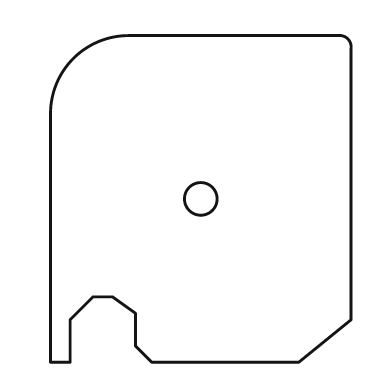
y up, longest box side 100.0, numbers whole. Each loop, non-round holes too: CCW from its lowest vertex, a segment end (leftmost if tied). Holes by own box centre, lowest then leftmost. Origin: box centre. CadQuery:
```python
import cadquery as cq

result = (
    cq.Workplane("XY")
    .moveTo(-46.0, -50.0)
    .lineTo(-40.0, -50.0)
    .lineTo(-40.0, -37.0)
    .lineTo(-33.0, -30.0)
    .lineTo(-27.0, -30.0)
    .lineTo(-20.0, -35.0)
    .lineTo(-20.0, -45.0)
    .lineTo(-15.0, -50.0)
    .lineTo(30.0, -50.0)
    .lineTo(46.0, -37.0)
    .lineTo(46.0, 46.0)
    .threePointArc((45.0, 49.0), (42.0, 50.0))
    .lineTo(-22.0, 50.0)
    .threePointArc((-39.0, 43.0), (-46.0, 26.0))
    .close()
    .moveTo(0.0, 0.0)
    .circle(5.0)
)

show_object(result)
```